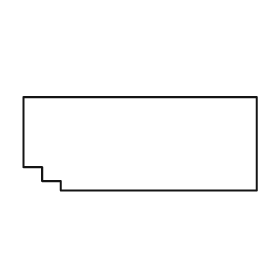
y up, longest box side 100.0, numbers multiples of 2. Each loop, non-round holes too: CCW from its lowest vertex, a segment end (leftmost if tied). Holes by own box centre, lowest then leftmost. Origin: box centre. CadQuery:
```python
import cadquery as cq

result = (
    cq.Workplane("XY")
    .moveTo(-34.0, -20.0)
    .lineTo(50.0, -20.0)
    .lineTo(50.0, 20.0)
    .lineTo(-50.0, 20.0)
    .lineTo(-50.0, -10.0)
    .lineTo(-42.0, -10.0)
    .lineTo(-42.0, -16.0)
    .lineTo(-34.0, -16.0)
    .close()
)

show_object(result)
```